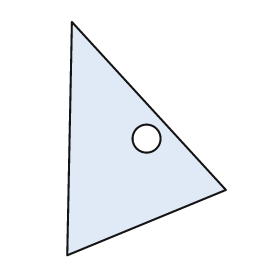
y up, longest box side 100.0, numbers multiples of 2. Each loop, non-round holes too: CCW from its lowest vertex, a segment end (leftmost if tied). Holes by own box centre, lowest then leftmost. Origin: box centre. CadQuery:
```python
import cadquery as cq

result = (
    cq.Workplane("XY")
    .moveTo(-34.0, -50.0)
    .lineTo(34.0, -22.0)
    .lineTo(-32.0, 50.0)
    .close()
    .moveTo(0.0, 0.0)
    .circle(6.0)
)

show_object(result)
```